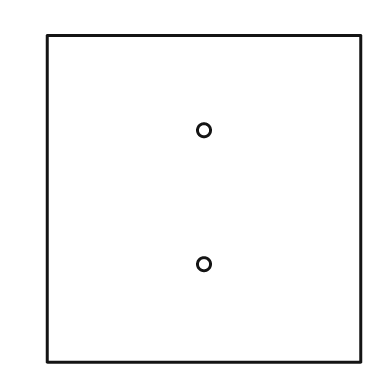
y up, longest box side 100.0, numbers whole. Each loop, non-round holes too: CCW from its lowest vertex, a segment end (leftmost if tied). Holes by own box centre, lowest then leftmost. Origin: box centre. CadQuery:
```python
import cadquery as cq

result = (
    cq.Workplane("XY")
    .moveTo(-48.0, -50.0)
    .lineTo(48.0, -50.0)
    .lineTo(48.0, 50.0)
    .lineTo(-48.0, 50.0)
    .close()
    .moveTo(0.0, -20.0)
    .circle(2.0)
    .moveTo(0.0, 21.0)
    .circle(2.0)
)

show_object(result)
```